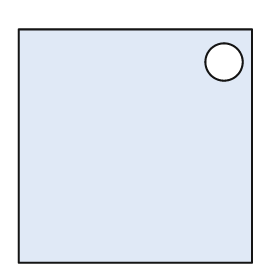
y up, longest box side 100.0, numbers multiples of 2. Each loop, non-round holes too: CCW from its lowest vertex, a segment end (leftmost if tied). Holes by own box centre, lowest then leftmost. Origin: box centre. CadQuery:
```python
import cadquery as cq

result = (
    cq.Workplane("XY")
    .moveTo(-50.0, -50.0)
    .lineTo(50.0, -50.0)
    .lineTo(50.0, 50.0)
    .lineTo(-50.0, 50.0)
    .close()
    .moveTo(38.0, 36.0)
    .circle(8.0)
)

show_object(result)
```